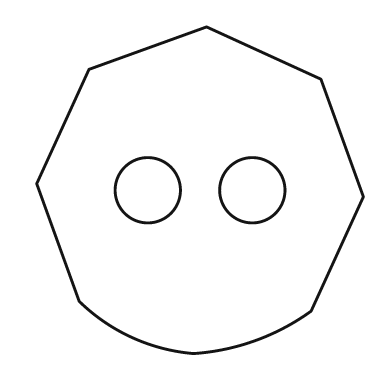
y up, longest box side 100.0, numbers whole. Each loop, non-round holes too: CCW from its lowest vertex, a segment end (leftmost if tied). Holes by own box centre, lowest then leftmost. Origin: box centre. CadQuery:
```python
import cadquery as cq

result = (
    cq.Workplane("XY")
    .moveTo(-2.0, -50.0)
    .threePointArc((17.0, -46.0), (34.0, -37.0))
    .lineTo(50.0, -2.0)
    .lineTo(37.0, 34.0)
    .lineTo(2.0, 50.0)
    .lineTo(-34.0, 37.0)
    .lineTo(-50.0, 2.0)
    .lineTo(-37.0, -34.0)
    .threePointArc((-21.0, -45.0), (-2.0, -50.0))
    .close()
    .moveTo(-16.0, 0.0)
    .circle(10.0)
    .moveTo(16.0, 0.0)
    .circle(10.0)
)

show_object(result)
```